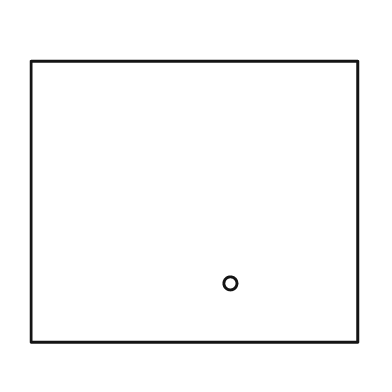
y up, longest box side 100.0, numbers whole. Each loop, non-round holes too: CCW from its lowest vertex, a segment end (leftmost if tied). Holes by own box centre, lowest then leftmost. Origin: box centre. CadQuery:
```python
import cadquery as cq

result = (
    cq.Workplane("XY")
    .moveTo(-50.0, -43.0)
    .lineTo(50.0, -43.0)
    .lineTo(50.0, 43.0)
    .lineTo(-50.0, 43.0)
    .close()
    .moveTo(11.0, -25.0)
    .circle(2.0)
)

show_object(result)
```